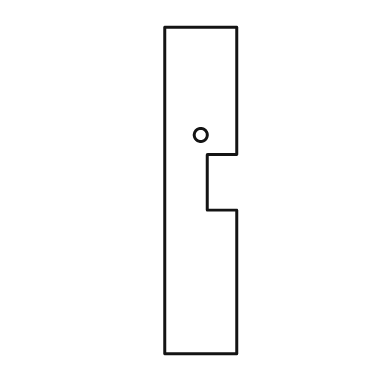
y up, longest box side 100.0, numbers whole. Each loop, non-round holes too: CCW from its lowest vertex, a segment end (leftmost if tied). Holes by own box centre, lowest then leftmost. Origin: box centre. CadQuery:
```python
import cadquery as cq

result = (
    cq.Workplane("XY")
    .moveTo(-11.0, -50.0)
    .lineTo(11.0, -50.0)
    .lineTo(11.0, -6.0)
    .lineTo(2.0, -6.0)
    .lineTo(2.0, 11.0)
    .lineTo(11.0, 11.0)
    .lineTo(11.0, 50.0)
    .lineTo(-11.0, 50.0)
    .close()
    .moveTo(0.0, 17.0)
    .circle(2.0)
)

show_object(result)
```